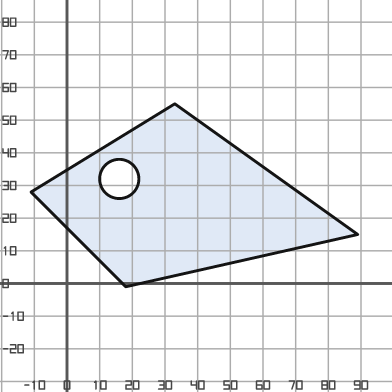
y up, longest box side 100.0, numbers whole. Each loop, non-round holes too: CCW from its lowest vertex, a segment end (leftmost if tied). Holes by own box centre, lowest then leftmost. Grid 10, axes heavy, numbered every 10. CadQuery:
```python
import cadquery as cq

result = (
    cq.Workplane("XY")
    .moveTo(18.0, -1.0)
    .lineTo(89.0, 15.0)
    .lineTo(33.0, 55.0)
    .lineTo(-11.0, 28.0)
    .close()
    .moveTo(16.0, 32.0)
    .circle(6.0)
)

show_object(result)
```